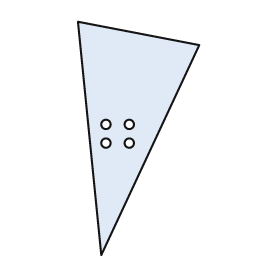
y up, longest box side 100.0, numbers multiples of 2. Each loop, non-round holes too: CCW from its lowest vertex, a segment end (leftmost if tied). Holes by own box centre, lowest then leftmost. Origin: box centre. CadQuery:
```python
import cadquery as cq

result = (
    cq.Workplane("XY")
    .moveTo(-16.0, -50.0)
    .lineTo(26.0, 40.0)
    .lineTo(-26.0, 50.0)
    .close()
    .moveTo(-14.0, -2.0)
    .circle(2.0)
    .moveTo(-4.0, -2.0)
    .circle(2.0)
    .moveTo(-14.0, 6.0)
    .circle(2.0)
    .moveTo(-4.0, 6.0)
    .circle(2.0)
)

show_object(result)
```